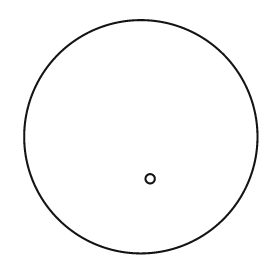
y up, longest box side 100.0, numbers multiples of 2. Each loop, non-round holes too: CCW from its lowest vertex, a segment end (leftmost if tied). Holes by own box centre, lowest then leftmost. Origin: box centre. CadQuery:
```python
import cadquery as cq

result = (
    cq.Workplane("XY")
    .moveTo(0.0, 0.0)
    .circle(50.0)
    .moveTo(4.0, -18.0)
    .circle(2.0)
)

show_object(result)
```